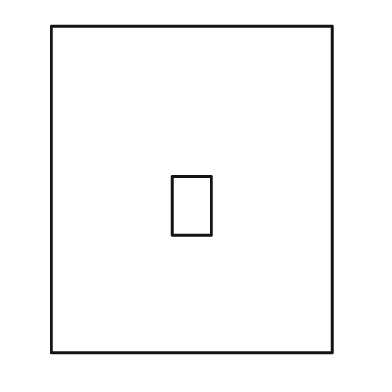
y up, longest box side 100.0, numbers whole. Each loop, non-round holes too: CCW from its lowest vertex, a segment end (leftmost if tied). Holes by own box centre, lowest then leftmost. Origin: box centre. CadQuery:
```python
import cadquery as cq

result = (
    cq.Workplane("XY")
    .moveTo(-43.0, -50.0)
    .lineTo(43.0, -50.0)
    .lineTo(43.0, 50.0)
    .lineTo(-43.0, 50.0)
    .close()
    .moveTo(-6.0, -14.0)
    .lineTo(6.0, -14.0)
    .lineTo(6.0, 4.0)
    .lineTo(-6.0, 4.0)
    .close()
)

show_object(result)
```